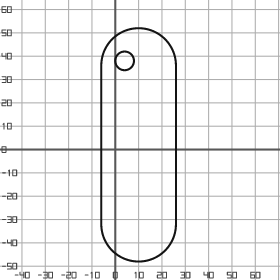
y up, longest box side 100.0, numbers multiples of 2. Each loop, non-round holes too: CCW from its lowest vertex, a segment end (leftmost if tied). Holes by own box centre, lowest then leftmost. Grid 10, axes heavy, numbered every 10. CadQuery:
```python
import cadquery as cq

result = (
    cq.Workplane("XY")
    .moveTo(-6.0, -32.0)
    .threePointArc((10.0, -48.0), (26.0, -32.0))
    .lineTo(26.0, 36.0)
    .threePointArc((10.0, 52.0), (-6.0, 36.0))
    .close()
    .moveTo(4.0, 38.0)
    .circle(4.0)
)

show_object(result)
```